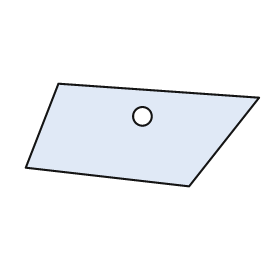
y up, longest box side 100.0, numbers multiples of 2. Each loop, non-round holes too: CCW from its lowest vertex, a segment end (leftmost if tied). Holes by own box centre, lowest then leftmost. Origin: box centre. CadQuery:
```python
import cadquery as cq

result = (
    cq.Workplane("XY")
    .moveTo(20.0, -22.0)
    .lineTo(50.0, 16.0)
    .lineTo(-36.0, 22.0)
    .lineTo(-50.0, -14.0)
    .close()
    .moveTo(0.0, 8.0)
    .circle(4.0)
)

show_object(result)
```